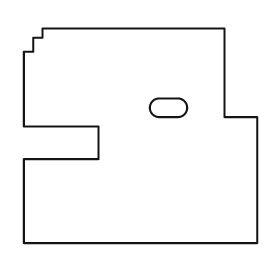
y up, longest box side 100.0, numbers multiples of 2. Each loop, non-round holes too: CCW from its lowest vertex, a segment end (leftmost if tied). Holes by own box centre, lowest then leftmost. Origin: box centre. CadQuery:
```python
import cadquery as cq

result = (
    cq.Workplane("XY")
    .moveTo(-50.0, -46.0)
    .lineTo(50.0, -46.0)
    .lineTo(50.0, 8.0)
    .lineTo(36.0, 8.0)
    .lineTo(36.0, 46.0)
    .lineTo(-42.0, 46.0)
    .lineTo(-42.0, 42.0)
    .lineTo(-46.0, 42.0)
    .lineTo(-46.0, 36.0)
    .lineTo(-50.0, 36.0)
    .lineTo(-50.0, 4.0)
    .lineTo(-18.0, 4.0)
    .lineTo(-18.0, -10.0)
    .lineTo(-50.0, -10.0)
    .close()
    .moveTo(8.0, 8.0)
    .lineTo(16.0, 8.0)
    .threePointArc((20.0, 12.0), (16.0, 16.0))
    .lineTo(8.0, 16.0)
    .threePointArc((4.0, 12.0), (8.0, 8.0))
    .close()
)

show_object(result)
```